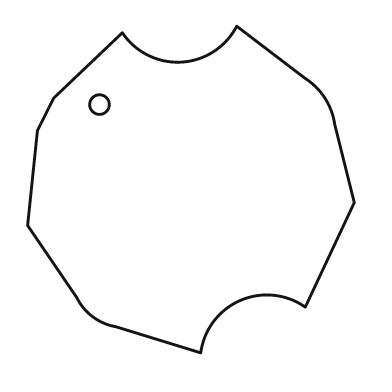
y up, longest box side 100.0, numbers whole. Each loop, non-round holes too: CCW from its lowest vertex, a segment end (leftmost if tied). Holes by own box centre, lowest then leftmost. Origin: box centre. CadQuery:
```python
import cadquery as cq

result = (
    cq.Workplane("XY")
    .moveTo(3.0, -50.0)
    .threePointArc((15.0, -34.0), (35.0, -36.0))
    .lineTo(50.0, -4.0)
    .lineTo(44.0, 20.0)
    .threePointArc((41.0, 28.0), (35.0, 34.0))
    .lineTo(14.0, 50.0)
    .threePointArc((-3.0, 39.0), (-21.0, 48.0))
    .lineTo(-42.0, 28.0)
    .lineTo(-47.0, 18.0)
    .lineTo(-50.0, -11.0)
    .lineTo(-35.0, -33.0)
    .threePointArc((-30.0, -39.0), (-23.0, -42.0))
    .close()
    .moveTo(-28.0, 26.0)
    .circle(3.0)
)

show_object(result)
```